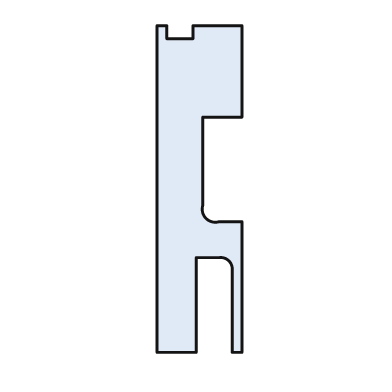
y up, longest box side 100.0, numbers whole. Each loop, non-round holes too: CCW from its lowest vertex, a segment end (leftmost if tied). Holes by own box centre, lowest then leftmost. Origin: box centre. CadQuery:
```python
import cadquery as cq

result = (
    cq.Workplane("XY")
    .moveTo(-13.0, -50.0)
    .lineTo(-1.0, -50.0)
    .lineTo(-1.0, -21.0)
    .lineTo(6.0, -21.0)
    .threePointArc((9.0, -22.0), (10.0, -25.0))
    .lineTo(10.0, -50.0)
    .lineTo(13.0, -50.0)
    .lineTo(13.0, -10.0)
    .lineTo(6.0, -10.0)
    .threePointArc((2.0, -9.0), (1.0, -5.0))
    .lineTo(1.0, 22.0)
    .lineTo(13.0, 22.0)
    .lineTo(13.0, 50.0)
    .lineTo(-2.0, 50.0)
    .lineTo(-2.0, 46.0)
    .lineTo(-10.0, 46.0)
    .lineTo(-10.0, 50.0)
    .lineTo(-13.0, 50.0)
    .close()
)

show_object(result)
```